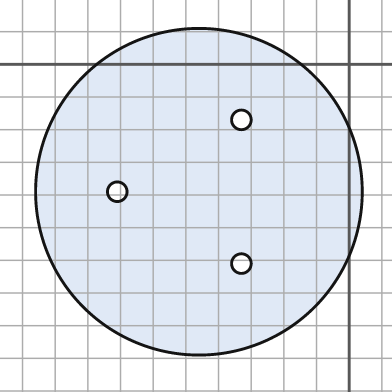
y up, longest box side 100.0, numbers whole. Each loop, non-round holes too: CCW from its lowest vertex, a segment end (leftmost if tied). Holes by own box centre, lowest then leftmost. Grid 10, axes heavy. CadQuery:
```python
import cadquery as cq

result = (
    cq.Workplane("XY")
    .moveTo(-46.0, -39.0)
    .circle(50.0)
    .moveTo(-33.0, -61.0)
    .circle(3.0)
    .moveTo(-71.0, -39.0)
    .circle(3.0)
    .moveTo(-33.0, -17.0)
    .circle(3.0)
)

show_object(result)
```